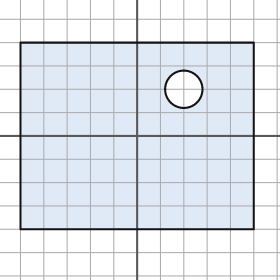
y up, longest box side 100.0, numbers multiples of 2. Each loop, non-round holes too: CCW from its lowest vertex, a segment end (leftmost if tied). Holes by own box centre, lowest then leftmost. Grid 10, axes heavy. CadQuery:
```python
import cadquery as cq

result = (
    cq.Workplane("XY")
    .moveTo(-50.0, -40.0)
    .lineTo(50.0, -40.0)
    .lineTo(50.0, 40.0)
    .lineTo(-50.0, 40.0)
    .close()
    .moveTo(20.0, 20.0)
    .circle(8.0)
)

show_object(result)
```